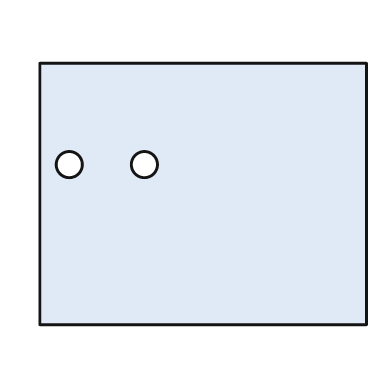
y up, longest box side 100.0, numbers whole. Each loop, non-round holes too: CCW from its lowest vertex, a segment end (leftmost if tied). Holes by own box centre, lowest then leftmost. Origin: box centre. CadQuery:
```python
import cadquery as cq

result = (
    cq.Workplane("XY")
    .moveTo(-50.0, -40.0)
    .lineTo(50.0, -40.0)
    .lineTo(50.0, 40.0)
    .lineTo(-50.0, 40.0)
    .close()
    .moveTo(-41.0, 9.0)
    .circle(4.0)
    .moveTo(-18.0, 9.0)
    .circle(4.0)
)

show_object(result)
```